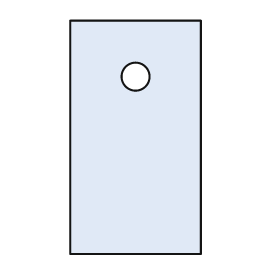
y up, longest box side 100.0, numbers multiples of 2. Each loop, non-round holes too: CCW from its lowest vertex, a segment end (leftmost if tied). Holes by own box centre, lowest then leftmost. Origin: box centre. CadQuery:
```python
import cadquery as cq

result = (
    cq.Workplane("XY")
    .moveTo(-28.0, -50.0)
    .lineTo(28.0, -50.0)
    .lineTo(28.0, 50.0)
    .lineTo(-28.0, 50.0)
    .close()
    .moveTo(0.0, 26.0)
    .circle(6.0)
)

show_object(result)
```